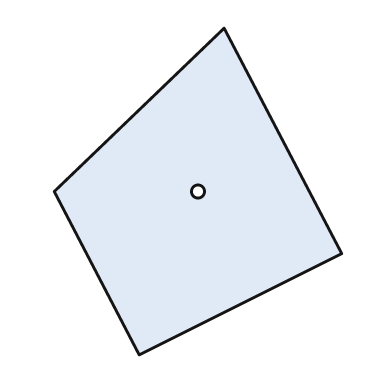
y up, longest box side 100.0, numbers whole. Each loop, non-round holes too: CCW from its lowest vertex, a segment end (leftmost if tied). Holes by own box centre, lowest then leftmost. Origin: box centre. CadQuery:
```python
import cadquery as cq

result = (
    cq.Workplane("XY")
    .moveTo(-18.0, -50.0)
    .lineTo(44.0, -19.0)
    .lineTo(8.0, 50.0)
    .lineTo(-44.0, 0.0)
    .close()
    .moveTo(0.0, 0.0)
    .circle(2.0)
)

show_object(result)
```